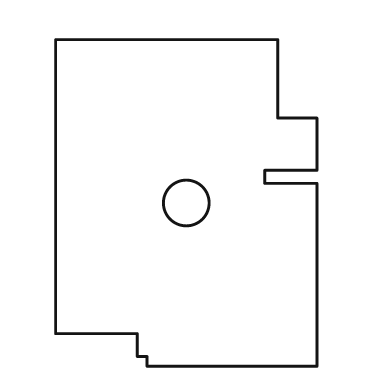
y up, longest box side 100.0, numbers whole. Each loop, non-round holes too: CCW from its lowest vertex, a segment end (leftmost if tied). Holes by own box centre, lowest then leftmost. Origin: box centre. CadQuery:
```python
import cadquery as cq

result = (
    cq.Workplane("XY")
    .moveTo(-12.0, -50.0)
    .lineTo(40.0, -50.0)
    .lineTo(40.0, 6.0)
    .lineTo(24.0, 6.0)
    .lineTo(24.0, 10.0)
    .lineTo(40.0, 10.0)
    .lineTo(40.0, 26.0)
    .lineTo(28.0, 26.0)
    .lineTo(28.0, 50.0)
    .lineTo(-40.0, 50.0)
    .lineTo(-40.0, -40.0)
    .lineTo(-15.0, -40.0)
    .lineTo(-15.0, -47.0)
    .lineTo(-12.0, -47.0)
    .close()
    .moveTo(0.0, 0.0)
    .circle(7.0)
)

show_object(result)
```